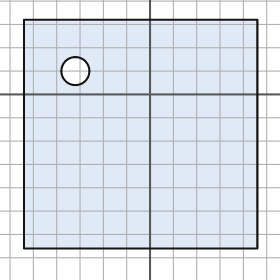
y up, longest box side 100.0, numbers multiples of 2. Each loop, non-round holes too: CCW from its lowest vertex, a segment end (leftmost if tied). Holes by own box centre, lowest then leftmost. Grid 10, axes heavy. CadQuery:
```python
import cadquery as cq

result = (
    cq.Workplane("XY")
    .moveTo(-54.0, -66.0)
    .lineTo(46.0, -66.0)
    .lineTo(46.0, 32.0)
    .lineTo(-54.0, 32.0)
    .close()
    .moveTo(-32.0, 10.0)
    .circle(6.0)
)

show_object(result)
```